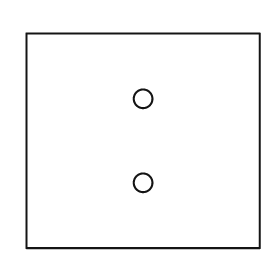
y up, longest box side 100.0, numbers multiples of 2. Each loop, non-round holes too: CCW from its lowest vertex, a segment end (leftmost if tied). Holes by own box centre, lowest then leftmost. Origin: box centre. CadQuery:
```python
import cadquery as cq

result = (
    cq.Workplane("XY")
    .moveTo(-50.0, -46.0)
    .lineTo(50.0, -46.0)
    .lineTo(50.0, 46.0)
    .lineTo(-50.0, 46.0)
    .close()
    .moveTo(0.0, -18.0)
    .circle(4.0)
    .moveTo(0.0, 18.0)
    .circle(4.0)
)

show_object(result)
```